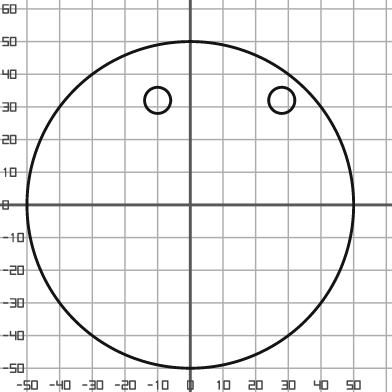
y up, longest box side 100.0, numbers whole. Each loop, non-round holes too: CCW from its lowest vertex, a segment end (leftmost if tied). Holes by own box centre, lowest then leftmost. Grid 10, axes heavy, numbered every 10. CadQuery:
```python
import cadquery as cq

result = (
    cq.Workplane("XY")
    .moveTo(0.0, 0.0)
    .circle(50.0)
    .moveTo(-10.0, 32.0)
    .circle(4.0)
    .moveTo(28.0, 32.0)
    .circle(4.0)
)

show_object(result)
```